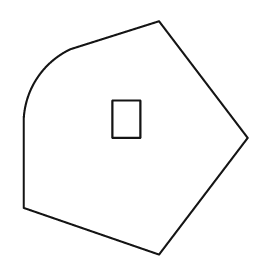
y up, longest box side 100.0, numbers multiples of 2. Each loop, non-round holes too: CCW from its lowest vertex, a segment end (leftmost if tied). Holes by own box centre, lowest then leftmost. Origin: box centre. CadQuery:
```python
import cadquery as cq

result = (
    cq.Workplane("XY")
    .moveTo(10.0, -50.0)
    .lineTo(48.0, 0.0)
    .lineTo(10.0, 50.0)
    .lineTo(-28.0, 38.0)
    .threePointArc((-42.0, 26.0), (-48.0, 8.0))
    .lineTo(-48.0, -30.0)
    .close()
    .moveTo(-10.0, 0.0)
    .lineTo(2.0, 0.0)
    .lineTo(2.0, 16.0)
    .lineTo(-10.0, 16.0)
    .close()
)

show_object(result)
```